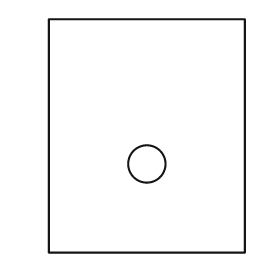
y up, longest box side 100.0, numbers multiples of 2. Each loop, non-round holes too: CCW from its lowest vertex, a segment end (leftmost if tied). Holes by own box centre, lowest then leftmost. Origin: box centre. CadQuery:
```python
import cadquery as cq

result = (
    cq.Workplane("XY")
    .moveTo(-42.0, -50.0)
    .lineTo(42.0, -50.0)
    .lineTo(42.0, 50.0)
    .lineTo(-42.0, 50.0)
    .close()
    .moveTo(0.0, -12.0)
    .circle(8.0)
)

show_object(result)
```